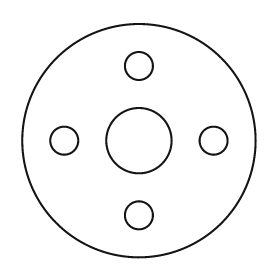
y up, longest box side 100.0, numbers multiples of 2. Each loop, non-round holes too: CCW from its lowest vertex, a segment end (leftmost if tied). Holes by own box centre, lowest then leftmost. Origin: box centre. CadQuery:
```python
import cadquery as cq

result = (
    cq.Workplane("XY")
    .moveTo(0.0, 0.0)
    .circle(50.0)
    .moveTo(0.0, -32.0)
    .circle(6.0)
    .moveTo(-32.0, 0.0)
    .circle(6.0)
    .moveTo(0.0, 0.0)
    .circle(14.0)
    .moveTo(32.0, 0.0)
    .circle(6.0)
    .moveTo(0.0, 32.0)
    .circle(6.0)
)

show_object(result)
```